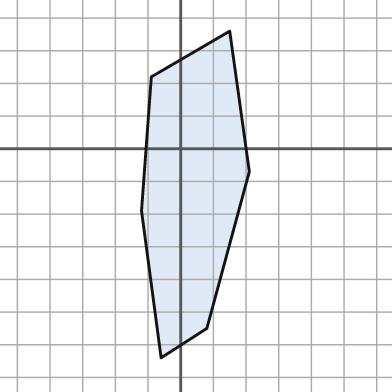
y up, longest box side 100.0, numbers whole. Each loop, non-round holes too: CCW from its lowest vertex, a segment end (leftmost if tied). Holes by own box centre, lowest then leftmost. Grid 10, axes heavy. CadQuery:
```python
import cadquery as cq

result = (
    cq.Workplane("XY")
    .moveTo(-6.0, -64.0)
    .lineTo(8.0, -55.0)
    .lineTo(21.0, -7.0)
    .lineTo(15.0, 36.0)
    .lineTo(-9.0, 22.0)
    .lineTo(-12.0, -19.0)
    .close()
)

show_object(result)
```